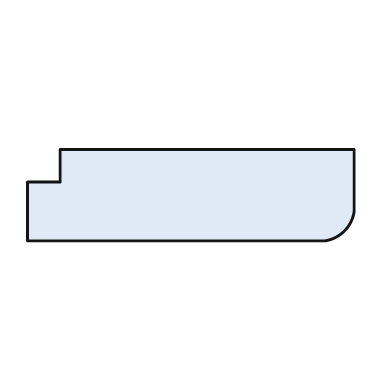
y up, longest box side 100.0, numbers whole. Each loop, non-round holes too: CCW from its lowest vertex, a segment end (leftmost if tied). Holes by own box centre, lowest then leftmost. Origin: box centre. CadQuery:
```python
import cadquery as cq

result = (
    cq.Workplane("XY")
    .moveTo(-50.0, -14.0)
    .lineTo(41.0, -14.0)
    .threePointArc((47.0, -11.0), (50.0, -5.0))
    .lineTo(50.0, 14.0)
    .lineTo(-40.0, 14.0)
    .lineTo(-40.0, 4.0)
    .lineTo(-50.0, 4.0)
    .close()
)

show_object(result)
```